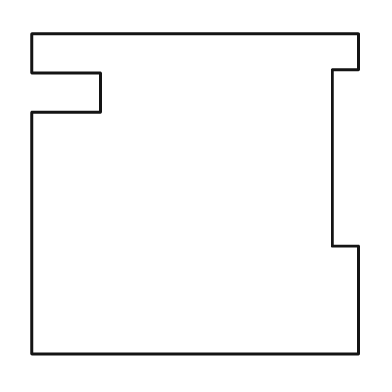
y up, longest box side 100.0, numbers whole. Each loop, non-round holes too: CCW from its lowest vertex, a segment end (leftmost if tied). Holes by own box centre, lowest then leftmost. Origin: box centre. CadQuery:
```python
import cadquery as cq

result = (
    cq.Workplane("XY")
    .moveTo(-50.0, -49.0)
    .lineTo(50.0, -49.0)
    .lineTo(50.0, -16.0)
    .lineTo(42.0, -16.0)
    .lineTo(42.0, 38.0)
    .lineTo(50.0, 38.0)
    .lineTo(50.0, 49.0)
    .lineTo(-50.0, 49.0)
    .lineTo(-50.0, 37.0)
    .lineTo(-29.0, 37.0)
    .lineTo(-29.0, 25.0)
    .lineTo(-50.0, 25.0)
    .close()
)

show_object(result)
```